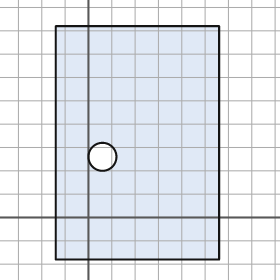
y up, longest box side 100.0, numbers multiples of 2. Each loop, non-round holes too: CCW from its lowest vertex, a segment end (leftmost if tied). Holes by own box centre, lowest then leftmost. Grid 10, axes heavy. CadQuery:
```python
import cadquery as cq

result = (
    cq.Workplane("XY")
    .moveTo(-14.0, -18.0)
    .lineTo(56.0, -18.0)
    .lineTo(56.0, 82.0)
    .lineTo(-14.0, 82.0)
    .close()
    .moveTo(6.0, 26.0)
    .circle(6.0)
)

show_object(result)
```